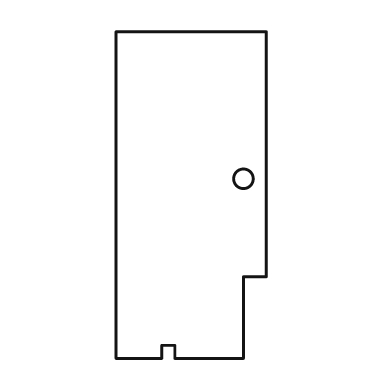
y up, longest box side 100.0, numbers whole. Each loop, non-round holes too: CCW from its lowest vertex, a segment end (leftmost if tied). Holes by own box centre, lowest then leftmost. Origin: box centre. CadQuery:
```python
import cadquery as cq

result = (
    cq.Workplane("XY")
    .moveTo(-23.0, -50.0)
    .lineTo(-9.0, -50.0)
    .lineTo(-9.0, -46.0)
    .lineTo(-5.0, -46.0)
    .lineTo(-5.0, -50.0)
    .lineTo(16.0, -50.0)
    .lineTo(16.0, -25.0)
    .lineTo(23.0, -25.0)
    .lineTo(23.0, 50.0)
    .lineTo(-23.0, 50.0)
    .close()
    .moveTo(16.0, 5.0)
    .circle(3.0)
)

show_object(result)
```